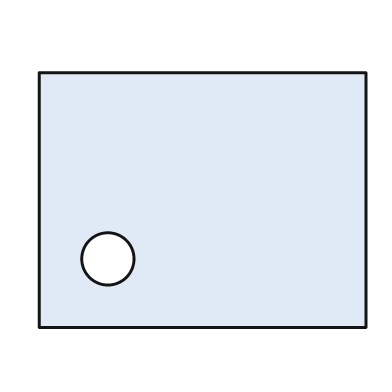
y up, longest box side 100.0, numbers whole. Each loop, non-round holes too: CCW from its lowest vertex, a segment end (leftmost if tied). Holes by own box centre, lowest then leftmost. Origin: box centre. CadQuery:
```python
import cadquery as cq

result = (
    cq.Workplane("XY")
    .moveTo(-50.0, -39.0)
    .lineTo(50.0, -39.0)
    .lineTo(50.0, 39.0)
    .lineTo(-50.0, 39.0)
    .close()
    .moveTo(-29.0, -18.0)
    .circle(8.0)
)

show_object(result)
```